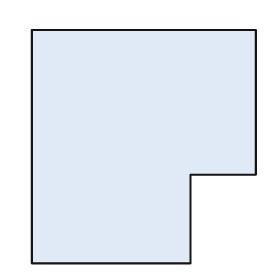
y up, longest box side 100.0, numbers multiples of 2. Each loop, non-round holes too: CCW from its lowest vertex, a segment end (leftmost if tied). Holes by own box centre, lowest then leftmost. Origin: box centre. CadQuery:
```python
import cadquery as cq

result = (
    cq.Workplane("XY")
    .moveTo(-48.0, -50.0)
    .lineTo(20.0, -50.0)
    .lineTo(20.0, -12.0)
    .lineTo(48.0, -12.0)
    .lineTo(48.0, 50.0)
    .lineTo(-48.0, 50.0)
    .close()
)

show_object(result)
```